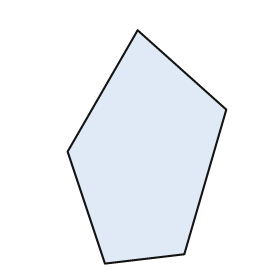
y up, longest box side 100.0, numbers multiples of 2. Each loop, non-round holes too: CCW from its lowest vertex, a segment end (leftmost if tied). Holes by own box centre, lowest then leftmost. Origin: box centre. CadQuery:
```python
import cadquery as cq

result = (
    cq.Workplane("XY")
    .moveTo(-18.0, -50.0)
    .lineTo(16.0, -46.0)
    .lineTo(34.0, 16.0)
    .lineTo(-4.0, 50.0)
    .lineTo(-34.0, -2.0)
    .close()
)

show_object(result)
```